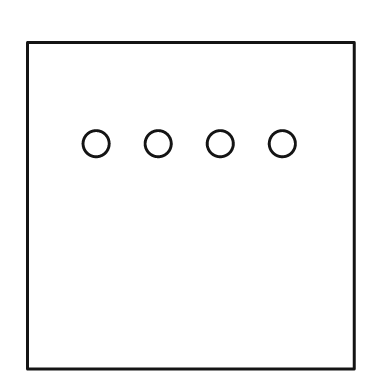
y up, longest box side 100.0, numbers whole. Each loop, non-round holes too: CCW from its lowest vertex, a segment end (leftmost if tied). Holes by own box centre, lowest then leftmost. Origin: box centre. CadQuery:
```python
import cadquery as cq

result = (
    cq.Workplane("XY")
    .moveTo(-50.0, -50.0)
    .lineTo(50.0, -50.0)
    .lineTo(50.0, 50.0)
    .lineTo(-50.0, 50.0)
    .close()
    .moveTo(-29.0, 19.0)
    .circle(4.0)
    .moveTo(-10.0, 19.0)
    .circle(4.0)
    .moveTo(9.0, 19.0)
    .circle(4.0)
    .moveTo(28.0, 19.0)
    .circle(4.0)
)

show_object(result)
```